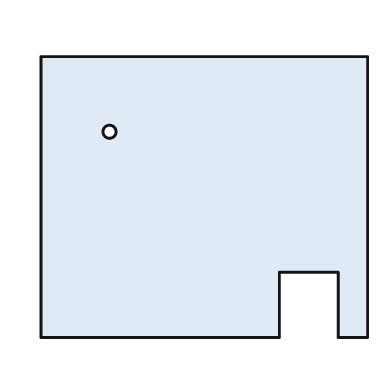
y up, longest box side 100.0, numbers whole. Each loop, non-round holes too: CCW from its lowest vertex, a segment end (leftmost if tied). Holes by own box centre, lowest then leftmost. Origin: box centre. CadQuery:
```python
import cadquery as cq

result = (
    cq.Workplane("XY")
    .moveTo(-50.0, -43.0)
    .lineTo(23.0, -43.0)
    .lineTo(23.0, -23.0)
    .lineTo(41.0, -23.0)
    .lineTo(41.0, -43.0)
    .lineTo(50.0, -43.0)
    .lineTo(50.0, 43.0)
    .lineTo(-50.0, 43.0)
    .close()
    .moveTo(-29.0, 20.0)
    .circle(2.0)
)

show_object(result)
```